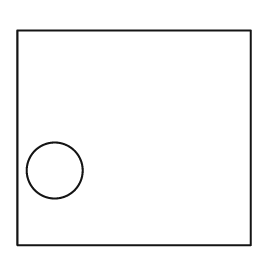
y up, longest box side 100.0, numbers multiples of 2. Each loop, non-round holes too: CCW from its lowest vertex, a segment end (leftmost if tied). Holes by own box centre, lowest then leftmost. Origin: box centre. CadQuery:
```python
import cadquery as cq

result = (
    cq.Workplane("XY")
    .moveTo(-50.0, -46.0)
    .lineTo(50.0, -46.0)
    .lineTo(50.0, 46.0)
    .lineTo(-50.0, 46.0)
    .close()
    .moveTo(-34.0, -14.0)
    .circle(12.0)
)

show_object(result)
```